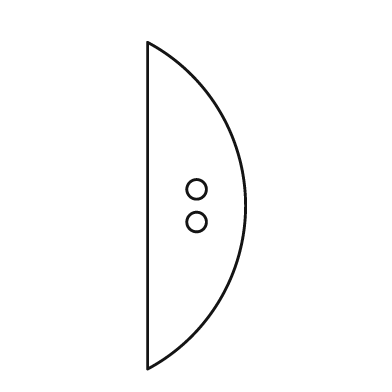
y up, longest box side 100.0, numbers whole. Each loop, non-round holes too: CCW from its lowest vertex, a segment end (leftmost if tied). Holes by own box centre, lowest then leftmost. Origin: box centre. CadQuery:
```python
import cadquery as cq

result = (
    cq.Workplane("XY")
    .moveTo(-15.0, -50.0)
    .threePointArc((15.0, 0.0), (-15.0, 50.0))
    .close()
    .moveTo(0.0, -5.0)
    .circle(3.0)
    .moveTo(0.0, 5.0)
    .circle(3.0)
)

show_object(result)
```